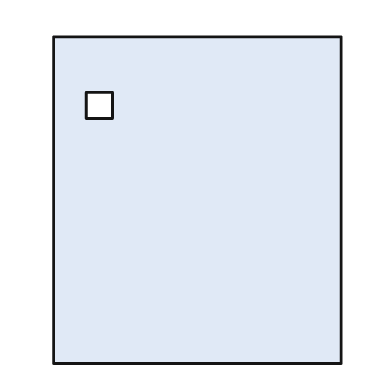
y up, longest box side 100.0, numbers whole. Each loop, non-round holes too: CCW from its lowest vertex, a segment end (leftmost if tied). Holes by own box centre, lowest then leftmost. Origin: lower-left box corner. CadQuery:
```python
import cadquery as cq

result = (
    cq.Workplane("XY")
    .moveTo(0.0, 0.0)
    .lineTo(88.0, 0.0)
    .lineTo(88.0, 100.0)
    .lineTo(0.0, 100.0)
    .close()
    .moveTo(10.0, 75.0)
    .lineTo(18.0, 75.0)
    .lineTo(18.0, 83.0)
    .lineTo(10.0, 83.0)
    .close()
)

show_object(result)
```